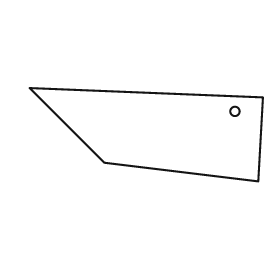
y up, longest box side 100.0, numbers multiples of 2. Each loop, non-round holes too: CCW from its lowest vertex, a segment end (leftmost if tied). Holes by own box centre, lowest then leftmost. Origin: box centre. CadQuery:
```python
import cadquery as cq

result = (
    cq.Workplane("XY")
    .moveTo(48.0, -20.0)
    .lineTo(50.0, 16.0)
    .lineTo(-50.0, 20.0)
    .lineTo(-18.0, -12.0)
    .close()
    .moveTo(38.0, 10.0)
    .circle(2.0)
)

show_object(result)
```